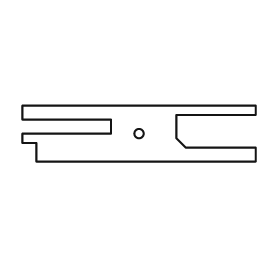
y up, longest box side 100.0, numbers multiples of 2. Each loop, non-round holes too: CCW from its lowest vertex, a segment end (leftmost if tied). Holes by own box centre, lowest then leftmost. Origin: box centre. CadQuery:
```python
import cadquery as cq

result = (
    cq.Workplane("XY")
    .moveTo(-44.0, -12.0)
    .lineTo(50.0, -12.0)
    .lineTo(50.0, -6.0)
    .lineTo(20.0, -6.0)
    .lineTo(16.0, -2.0)
    .lineTo(16.0, 8.0)
    .lineTo(50.0, 8.0)
    .lineTo(50.0, 12.0)
    .lineTo(-50.0, 12.0)
    .lineTo(-50.0, 6.0)
    .lineTo(-12.0, 6.0)
    .lineTo(-12.0, 0.0)
    .lineTo(-50.0, 0.0)
    .lineTo(-50.0, -4.0)
    .lineTo(-44.0, -4.0)
    .close()
    .moveTo(0.0, 0.0)
    .circle(2.0)
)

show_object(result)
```